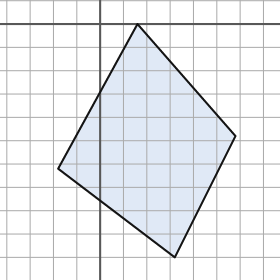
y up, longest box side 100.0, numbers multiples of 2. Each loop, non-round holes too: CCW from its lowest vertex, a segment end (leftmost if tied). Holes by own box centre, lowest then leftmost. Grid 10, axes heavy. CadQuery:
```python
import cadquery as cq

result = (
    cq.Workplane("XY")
    .moveTo(32.0, -100.0)
    .lineTo(58.0, -48.0)
    .lineTo(16.0, 0.0)
    .lineTo(-18.0, -62.0)
    .close()
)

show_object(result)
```